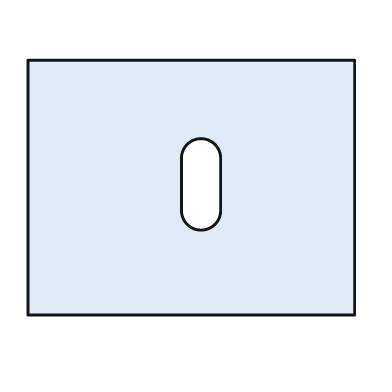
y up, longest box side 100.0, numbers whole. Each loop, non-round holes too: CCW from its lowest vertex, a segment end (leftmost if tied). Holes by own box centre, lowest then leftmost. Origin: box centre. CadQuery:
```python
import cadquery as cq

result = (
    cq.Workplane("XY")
    .moveTo(-50.0, -39.0)
    .lineTo(50.0, -39.0)
    .lineTo(50.0, 39.0)
    .lineTo(-50.0, 39.0)
    .close()
    .moveTo(-3.0, -7.0)
    .threePointArc((3.0, -13.0), (9.0, -7.0))
    .lineTo(9.0, 9.0)
    .threePointArc((3.0, 15.0), (-3.0, 9.0))
    .close()
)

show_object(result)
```